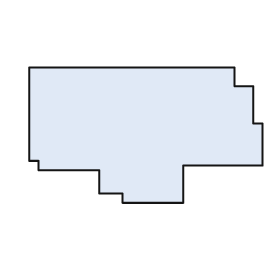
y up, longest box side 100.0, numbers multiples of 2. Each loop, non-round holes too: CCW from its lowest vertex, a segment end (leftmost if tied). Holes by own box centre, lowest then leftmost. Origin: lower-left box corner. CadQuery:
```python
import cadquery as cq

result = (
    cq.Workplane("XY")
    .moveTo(40.0, 0.0)
    .lineTo(66.0, 0.0)
    .lineTo(66.0, 16.0)
    .lineTo(100.0, 16.0)
    .lineTo(100.0, 34.0)
    .lineTo(96.0, 34.0)
    .lineTo(96.0, 50.0)
    .lineTo(88.0, 50.0)
    .lineTo(88.0, 58.0)
    .lineTo(0.0, 58.0)
    .lineTo(0.0, 18.0)
    .lineTo(4.0, 18.0)
    .lineTo(4.0, 14.0)
    .lineTo(30.0, 14.0)
    .lineTo(30.0, 4.0)
    .lineTo(40.0, 4.0)
    .close()
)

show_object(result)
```